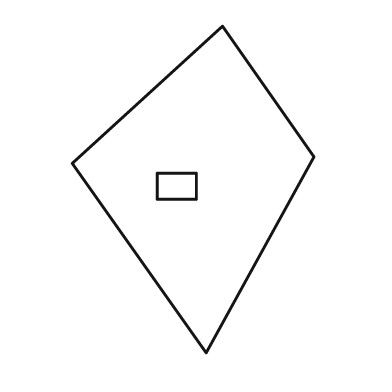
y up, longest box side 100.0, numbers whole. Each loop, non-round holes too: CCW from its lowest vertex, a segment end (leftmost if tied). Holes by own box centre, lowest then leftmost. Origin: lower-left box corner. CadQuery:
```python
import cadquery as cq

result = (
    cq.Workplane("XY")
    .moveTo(41.0, 0.0)
    .lineTo(74.0, 60.0)
    .lineTo(46.0, 100.0)
    .lineTo(0.0, 58.0)
    .close()
    .moveTo(26.0, 47.0)
    .lineTo(38.0, 47.0)
    .lineTo(38.0, 55.0)
    .lineTo(26.0, 55.0)
    .close()
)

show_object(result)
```